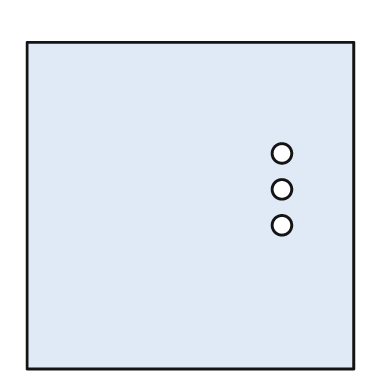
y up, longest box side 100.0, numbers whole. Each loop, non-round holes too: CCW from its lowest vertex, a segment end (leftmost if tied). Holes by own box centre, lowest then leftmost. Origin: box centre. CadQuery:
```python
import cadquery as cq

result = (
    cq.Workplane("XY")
    .moveTo(-50.0, -50.0)
    .lineTo(50.0, -50.0)
    .lineTo(50.0, 50.0)
    .lineTo(-50.0, 50.0)
    .close()
    .moveTo(28.0, -6.0)
    .circle(3.0)
    .moveTo(28.0, 5.0)
    .circle(3.0)
    .moveTo(28.0, 16.0)
    .circle(3.0)
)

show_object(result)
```